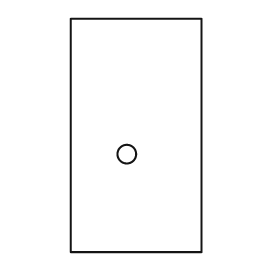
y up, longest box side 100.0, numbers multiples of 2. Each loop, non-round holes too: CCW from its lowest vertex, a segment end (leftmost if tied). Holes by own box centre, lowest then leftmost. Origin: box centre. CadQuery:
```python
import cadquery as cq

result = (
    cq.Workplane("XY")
    .moveTo(-28.0, -50.0)
    .lineTo(28.0, -50.0)
    .lineTo(28.0, 50.0)
    .lineTo(-28.0, 50.0)
    .close()
    .moveTo(-4.0, -8.0)
    .circle(4.0)
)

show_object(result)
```